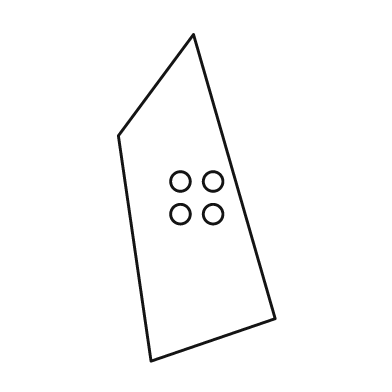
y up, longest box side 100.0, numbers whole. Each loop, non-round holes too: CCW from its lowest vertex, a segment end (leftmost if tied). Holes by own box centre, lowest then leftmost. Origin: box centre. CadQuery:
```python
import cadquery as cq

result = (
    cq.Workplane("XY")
    .moveTo(-14.0, -50.0)
    .lineTo(24.0, -37.0)
    .lineTo(-1.0, 50.0)
    .lineTo(-24.0, 19.0)
    .close()
    .moveTo(-5.0, -5.0)
    .circle(3.0)
    .moveTo(5.0, -5.0)
    .circle(3.0)
    .moveTo(-5.0, 5.0)
    .circle(3.0)
    .moveTo(5.0, 5.0)
    .circle(3.0)
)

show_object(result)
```